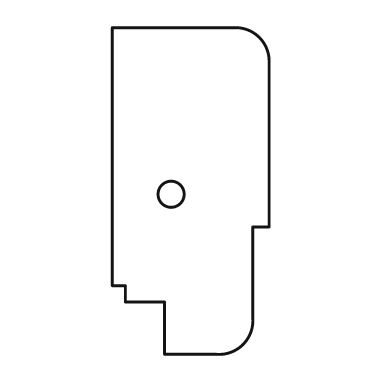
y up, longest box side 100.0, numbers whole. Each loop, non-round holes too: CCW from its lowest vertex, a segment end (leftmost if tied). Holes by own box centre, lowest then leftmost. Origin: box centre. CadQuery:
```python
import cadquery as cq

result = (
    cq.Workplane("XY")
    .moveTo(-8.0, -50.0)
    .lineTo(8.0, -50.0)
    .threePointArc((16.0, -47.0), (19.0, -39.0))
    .lineTo(19.0, -11.0)
    .lineTo(24.0, -11.0)
    .lineTo(24.0, 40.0)
    .threePointArc((21.0, 47.0), (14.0, 50.0))
    .lineTo(-24.0, 50.0)
    .lineTo(-24.0, -29.0)
    .lineTo(-20.0, -29.0)
    .lineTo(-20.0, -34.0)
    .lineTo(-8.0, -34.0)
    .close()
    .moveTo(-6.0, -1.0)
    .circle(4.0)
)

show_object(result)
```